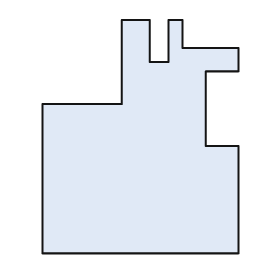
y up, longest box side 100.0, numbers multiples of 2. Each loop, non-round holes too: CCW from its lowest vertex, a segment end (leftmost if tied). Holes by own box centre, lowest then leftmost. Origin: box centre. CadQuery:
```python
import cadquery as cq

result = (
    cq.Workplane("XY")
    .moveTo(-42.0, -50.0)
    .lineTo(42.0, -50.0)
    .lineTo(42.0, -4.0)
    .lineTo(28.0, -4.0)
    .lineTo(28.0, 28.0)
    .lineTo(42.0, 28.0)
    .lineTo(42.0, 38.0)
    .lineTo(18.0, 38.0)
    .lineTo(18.0, 50.0)
    .lineTo(12.0, 50.0)
    .lineTo(12.0, 32.0)
    .lineTo(4.0, 32.0)
    .lineTo(4.0, 50.0)
    .lineTo(-8.0, 50.0)
    .lineTo(-8.0, 14.0)
    .lineTo(-42.0, 14.0)
    .close()
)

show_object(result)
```